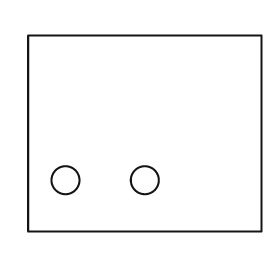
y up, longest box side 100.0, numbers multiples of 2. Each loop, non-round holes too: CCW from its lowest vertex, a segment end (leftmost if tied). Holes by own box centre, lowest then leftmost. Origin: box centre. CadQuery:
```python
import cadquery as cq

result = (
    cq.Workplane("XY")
    .moveTo(-50.0, -42.0)
    .lineTo(50.0, -42.0)
    .lineTo(50.0, 42.0)
    .lineTo(-50.0, 42.0)
    .close()
    .moveTo(-34.0, -20.0)
    .circle(6.0)
    .moveTo(0.0, -20.0)
    .circle(6.0)
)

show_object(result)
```